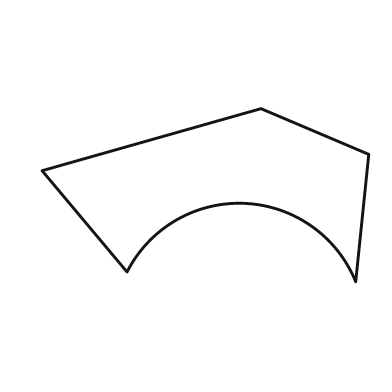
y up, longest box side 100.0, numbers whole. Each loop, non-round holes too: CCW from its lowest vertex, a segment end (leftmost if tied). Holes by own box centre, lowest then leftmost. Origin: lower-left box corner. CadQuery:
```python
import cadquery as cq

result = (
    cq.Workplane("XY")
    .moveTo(96.0, 0.0)
    .lineTo(100.0, 39.0)
    .lineTo(67.0, 53.0)
    .lineTo(0.0, 34.0)
    .lineTo(26.0, 3.0)
    .threePointArc((62.0, 24.0), (96.0, 0.0))
    .close()
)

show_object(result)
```